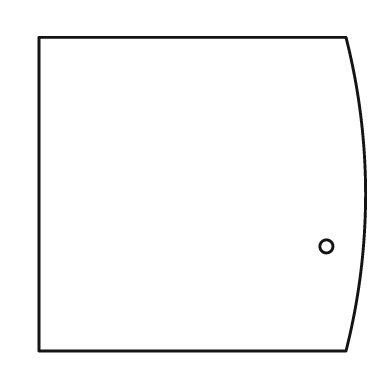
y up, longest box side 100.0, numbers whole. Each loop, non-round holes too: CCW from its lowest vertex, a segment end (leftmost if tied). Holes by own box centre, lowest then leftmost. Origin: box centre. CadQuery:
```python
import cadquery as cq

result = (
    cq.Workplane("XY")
    .moveTo(-50.0, -48.0)
    .lineTo(44.0, -48.0)
    .threePointArc((50.0, 0.0), (44.0, 48.0))
    .lineTo(-50.0, 48.0)
    .close()
    .moveTo(38.0, -16.0)
    .circle(2.0)
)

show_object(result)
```